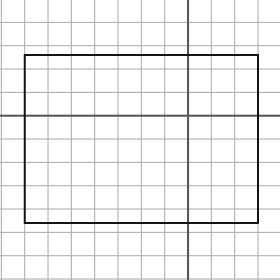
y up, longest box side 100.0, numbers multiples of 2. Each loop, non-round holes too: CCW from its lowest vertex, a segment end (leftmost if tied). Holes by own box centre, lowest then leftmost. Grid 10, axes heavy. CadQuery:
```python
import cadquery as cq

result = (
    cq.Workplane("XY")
    .moveTo(-70.0, -46.0)
    .lineTo(30.0, -46.0)
    .lineTo(30.0, 26.0)
    .lineTo(-70.0, 26.0)
    .close()
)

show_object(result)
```